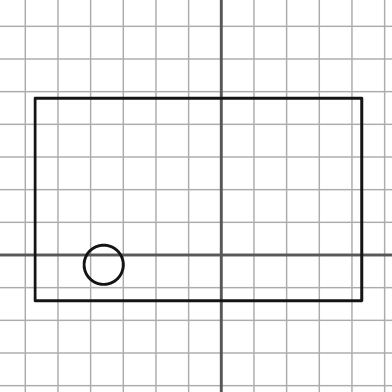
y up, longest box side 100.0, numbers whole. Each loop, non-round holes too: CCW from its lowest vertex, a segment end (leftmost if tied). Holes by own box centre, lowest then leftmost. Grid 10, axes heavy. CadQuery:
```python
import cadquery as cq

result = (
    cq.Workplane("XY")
    .moveTo(-57.0, -14.0)
    .lineTo(43.0, -14.0)
    .lineTo(43.0, 48.0)
    .lineTo(-57.0, 48.0)
    .close()
    .moveTo(-36.0, -3.0)
    .circle(6.0)
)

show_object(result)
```